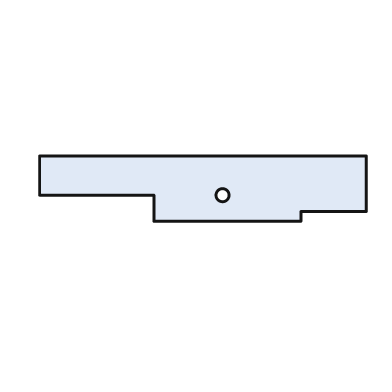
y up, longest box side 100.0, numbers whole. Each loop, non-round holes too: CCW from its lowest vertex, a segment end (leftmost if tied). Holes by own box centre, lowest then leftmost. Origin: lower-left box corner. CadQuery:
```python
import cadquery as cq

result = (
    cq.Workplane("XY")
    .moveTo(35.0, 0.0)
    .lineTo(80.0, 0.0)
    .lineTo(80.0, 3.0)
    .lineTo(100.0, 3.0)
    .lineTo(100.0, 20.0)
    .lineTo(0.0, 20.0)
    .lineTo(0.0, 8.0)
    .lineTo(35.0, 8.0)
    .close()
    .moveTo(56.0, 8.0)
    .circle(2.0)
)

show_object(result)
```